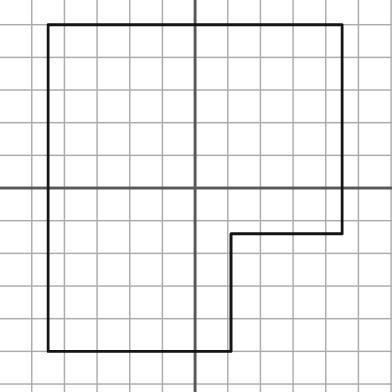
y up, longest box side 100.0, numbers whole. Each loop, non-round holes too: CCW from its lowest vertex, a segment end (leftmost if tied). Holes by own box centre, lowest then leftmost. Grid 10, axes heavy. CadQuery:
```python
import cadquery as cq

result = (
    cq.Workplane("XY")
    .moveTo(-45.0, -50.0)
    .lineTo(11.0, -50.0)
    .lineTo(11.0, -14.0)
    .lineTo(45.0, -14.0)
    .lineTo(45.0, 50.0)
    .lineTo(-45.0, 50.0)
    .close()
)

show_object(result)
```